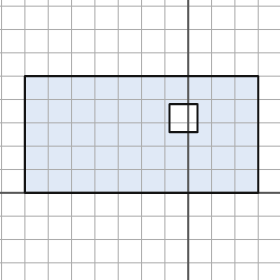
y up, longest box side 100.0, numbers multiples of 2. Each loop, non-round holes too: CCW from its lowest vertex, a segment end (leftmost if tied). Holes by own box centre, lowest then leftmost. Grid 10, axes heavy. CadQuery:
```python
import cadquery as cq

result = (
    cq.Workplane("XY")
    .moveTo(-70.0, 0.0)
    .lineTo(30.0, 0.0)
    .lineTo(30.0, 50.0)
    .lineTo(-70.0, 50.0)
    .close()
    .moveTo(-8.0, 26.0)
    .lineTo(4.0, 26.0)
    .lineTo(4.0, 38.0)
    .lineTo(-8.0, 38.0)
    .close()
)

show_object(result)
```